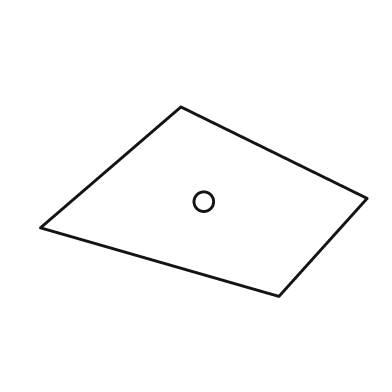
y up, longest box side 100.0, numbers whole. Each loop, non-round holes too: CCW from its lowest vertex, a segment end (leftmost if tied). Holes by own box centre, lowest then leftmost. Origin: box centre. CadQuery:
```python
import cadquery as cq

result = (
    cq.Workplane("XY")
    .moveTo(23.0, -29.0)
    .lineTo(50.0, 1.0)
    .lineTo(-7.0, 29.0)
    .lineTo(-50.0, -8.0)
    .close()
    .moveTo(0.0, 0.0)
    .circle(3.0)
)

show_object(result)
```